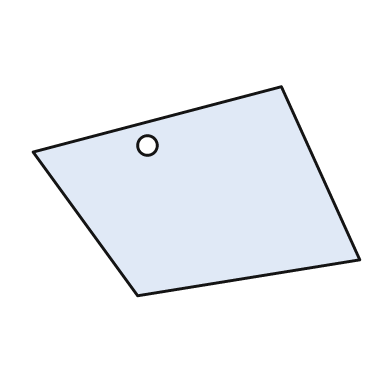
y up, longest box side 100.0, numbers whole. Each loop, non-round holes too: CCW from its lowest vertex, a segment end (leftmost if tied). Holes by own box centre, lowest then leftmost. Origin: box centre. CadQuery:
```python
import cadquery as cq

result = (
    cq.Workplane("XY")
    .moveTo(-18.0, -32.0)
    .lineTo(50.0, -21.0)
    .lineTo(26.0, 32.0)
    .lineTo(-50.0, 12.0)
    .close()
    .moveTo(-15.0, 14.0)
    .circle(3.0)
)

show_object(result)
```